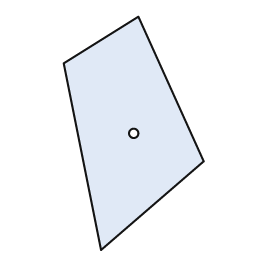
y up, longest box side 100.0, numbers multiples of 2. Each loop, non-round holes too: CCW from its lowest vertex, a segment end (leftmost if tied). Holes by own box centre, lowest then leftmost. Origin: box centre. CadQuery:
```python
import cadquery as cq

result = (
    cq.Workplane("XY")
    .moveTo(-14.0, -50.0)
    .lineTo(30.0, -12.0)
    .lineTo(2.0, 50.0)
    .lineTo(-30.0, 30.0)
    .close()
    .moveTo(0.0, 0.0)
    .circle(2.0)
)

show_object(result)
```